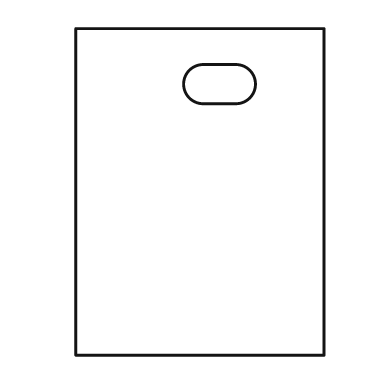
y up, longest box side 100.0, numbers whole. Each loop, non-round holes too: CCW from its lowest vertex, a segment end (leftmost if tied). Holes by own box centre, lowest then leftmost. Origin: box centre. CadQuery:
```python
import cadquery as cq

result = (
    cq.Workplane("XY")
    .moveTo(-38.0, -50.0)
    .lineTo(38.0, -50.0)
    .lineTo(38.0, 50.0)
    .lineTo(-38.0, 50.0)
    .close()
    .moveTo(1.0, 27.0)
    .lineTo(11.0, 27.0)
    .threePointArc((17.0, 33.0), (11.0, 39.0))
    .lineTo(1.0, 39.0)
    .threePointArc((-5.0, 33.0), (1.0, 27.0))
    .close()
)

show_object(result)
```